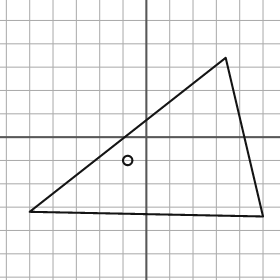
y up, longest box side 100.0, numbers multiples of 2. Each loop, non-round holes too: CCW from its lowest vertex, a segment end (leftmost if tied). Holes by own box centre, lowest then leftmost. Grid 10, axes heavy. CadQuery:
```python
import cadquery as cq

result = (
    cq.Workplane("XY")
    .moveTo(50.0, -34.0)
    .lineTo(34.0, 34.0)
    .lineTo(-50.0, -32.0)
    .close()
    .moveTo(-8.0, -10.0)
    .circle(2.0)
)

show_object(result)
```